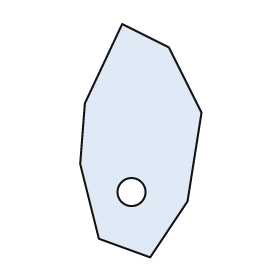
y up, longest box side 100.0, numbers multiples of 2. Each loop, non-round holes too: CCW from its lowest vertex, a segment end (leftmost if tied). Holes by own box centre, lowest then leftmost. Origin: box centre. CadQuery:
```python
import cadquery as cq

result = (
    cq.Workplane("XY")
    .moveTo(4.0, -50.0)
    .lineTo(20.0, -26.0)
    .lineTo(26.0, 12.0)
    .lineTo(12.0, 40.0)
    .lineTo(-8.0, 50.0)
    .lineTo(-24.0, 16.0)
    .lineTo(-26.0, -10.0)
    .lineTo(-18.0, -42.0)
    .close()
    .moveTo(-4.0, -22.0)
    .circle(6.0)
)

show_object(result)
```